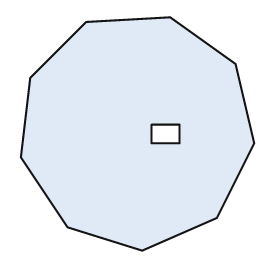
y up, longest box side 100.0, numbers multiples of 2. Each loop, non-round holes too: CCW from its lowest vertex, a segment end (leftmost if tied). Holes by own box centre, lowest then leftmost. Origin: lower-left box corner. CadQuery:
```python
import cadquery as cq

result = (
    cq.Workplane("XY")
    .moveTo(52.0, 0.0)
    .lineTo(84.0, 14.0)
    .lineTo(100.0, 46.0)
    .lineTo(92.0, 80.0)
    .lineTo(64.0, 100.0)
    .lineTo(28.0, 98.0)
    .lineTo(4.0, 74.0)
    .lineTo(0.0, 40.0)
    .lineTo(20.0, 10.0)
    .close()
    .moveTo(56.0, 46.0)
    .lineTo(68.0, 46.0)
    .lineTo(68.0, 54.0)
    .lineTo(56.0, 54.0)
    .close()
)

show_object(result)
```